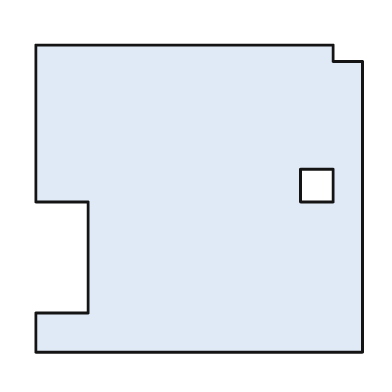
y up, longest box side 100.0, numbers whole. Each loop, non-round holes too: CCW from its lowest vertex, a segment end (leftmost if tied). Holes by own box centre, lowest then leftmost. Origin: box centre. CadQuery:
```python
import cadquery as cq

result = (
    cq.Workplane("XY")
    .moveTo(-50.0, -47.0)
    .lineTo(50.0, -47.0)
    .lineTo(50.0, 42.0)
    .lineTo(41.0, 42.0)
    .lineTo(41.0, 47.0)
    .lineTo(-50.0, 47.0)
    .lineTo(-50.0, -1.0)
    .lineTo(-34.0, -1.0)
    .lineTo(-34.0, -35.0)
    .lineTo(-50.0, -35.0)
    .close()
    .moveTo(31.0, -1.0)
    .lineTo(41.0, -1.0)
    .lineTo(41.0, 9.0)
    .lineTo(31.0, 9.0)
    .close()
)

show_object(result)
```